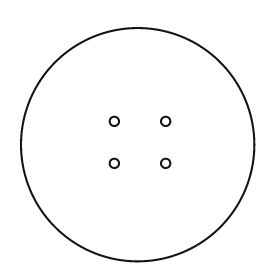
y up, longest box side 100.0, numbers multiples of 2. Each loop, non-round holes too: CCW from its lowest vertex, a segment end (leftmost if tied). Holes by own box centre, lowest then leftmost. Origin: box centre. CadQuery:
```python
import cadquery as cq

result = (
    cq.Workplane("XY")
    .moveTo(0.0, 0.0)
    .circle(50.0)
    .moveTo(-10.0, -8.0)
    .circle(2.0)
    .moveTo(12.0, -8.0)
    .circle(2.0)
    .moveTo(-10.0, 10.0)
    .circle(2.0)
    .moveTo(12.0, 10.0)
    .circle(2.0)
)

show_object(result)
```